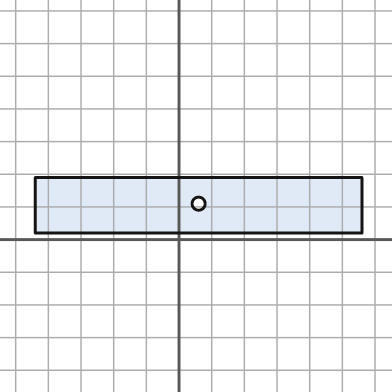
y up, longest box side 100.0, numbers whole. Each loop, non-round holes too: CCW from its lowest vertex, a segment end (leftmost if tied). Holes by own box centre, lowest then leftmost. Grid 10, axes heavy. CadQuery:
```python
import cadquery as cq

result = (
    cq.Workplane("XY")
    .moveTo(-44.0, 2.0)
    .lineTo(56.0, 2.0)
    .lineTo(56.0, 19.0)
    .lineTo(-44.0, 19.0)
    .close()
    .moveTo(6.0, 11.0)
    .circle(2.0)
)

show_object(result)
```